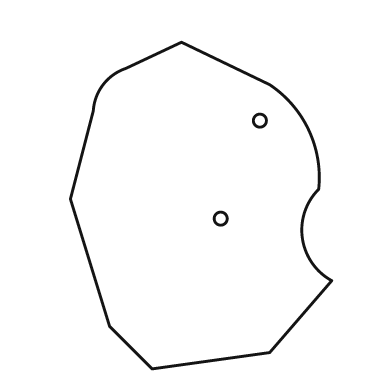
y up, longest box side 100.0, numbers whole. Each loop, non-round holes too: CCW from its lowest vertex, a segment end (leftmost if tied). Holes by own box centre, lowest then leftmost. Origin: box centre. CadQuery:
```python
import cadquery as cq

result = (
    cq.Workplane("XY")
    .moveTo(-15.0, -50.0)
    .lineTo(21.0, -45.0)
    .lineTo(40.0, -23.0)
    .threePointArc((31.0, -10.0), (36.0, 5.0))
    .threePointArc((33.0, 23.0), (21.0, 37.0))
    .lineTo(-6.0, 50.0)
    .lineTo(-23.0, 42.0)
    .threePointArc((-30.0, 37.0), (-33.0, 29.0))
    .lineTo(-40.0, 2.0)
    .lineTo(-28.0, -37.0)
    .close()
    .moveTo(6.0, -4.0)
    .circle(2.0)
    .moveTo(18.0, 26.0)
    .circle(2.0)
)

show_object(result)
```